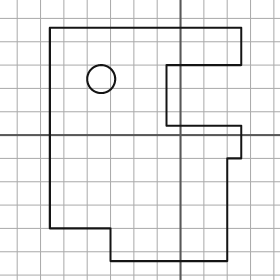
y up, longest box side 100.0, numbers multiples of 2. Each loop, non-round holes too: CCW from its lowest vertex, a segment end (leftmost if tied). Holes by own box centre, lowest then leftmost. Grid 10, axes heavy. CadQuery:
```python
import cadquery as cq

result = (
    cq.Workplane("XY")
    .moveTo(-30.0, -54.0)
    .lineTo(20.0, -54.0)
    .lineTo(20.0, -10.0)
    .lineTo(26.0, -10.0)
    .lineTo(26.0, 4.0)
    .lineTo(-6.0, 4.0)
    .lineTo(-6.0, 30.0)
    .lineTo(26.0, 30.0)
    .lineTo(26.0, 46.0)
    .lineTo(-56.0, 46.0)
    .lineTo(-56.0, -40.0)
    .lineTo(-30.0, -40.0)
    .close()
    .moveTo(-34.0, 24.0)
    .circle(6.0)
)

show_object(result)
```